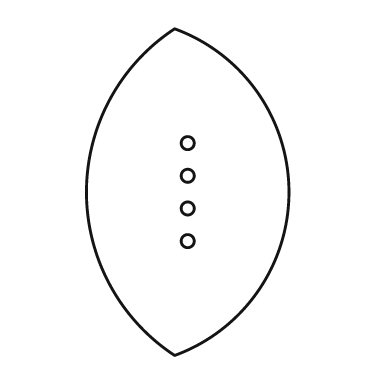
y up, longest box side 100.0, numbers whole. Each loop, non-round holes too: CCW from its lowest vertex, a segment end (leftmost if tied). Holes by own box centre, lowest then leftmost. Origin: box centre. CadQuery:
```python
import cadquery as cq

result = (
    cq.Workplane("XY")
    .moveTo(-4.0, -50.0)
    .threePointArc((31.0, 0.0), (-4.0, 50.0))
    .threePointArc((-31.0, 0.0), (-4.0, -50.0))
    .close()
    .moveTo(0.0, -15.0)
    .circle(2.0)
    .moveTo(0.0, -5.0)
    .circle(2.0)
    .moveTo(0.0, 5.0)
    .circle(2.0)
    .moveTo(0.0, 15.0)
    .circle(2.0)
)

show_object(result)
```